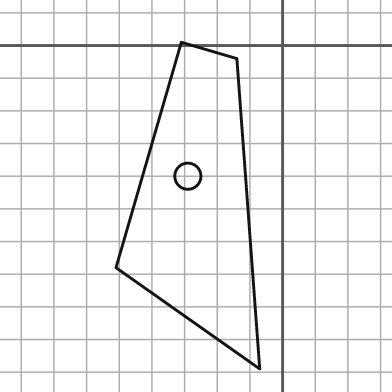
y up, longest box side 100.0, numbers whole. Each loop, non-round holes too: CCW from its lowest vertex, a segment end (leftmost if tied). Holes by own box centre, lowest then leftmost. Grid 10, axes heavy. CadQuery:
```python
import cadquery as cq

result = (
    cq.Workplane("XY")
    .moveTo(-7.0, -99.0)
    .lineTo(-14.0, -4.0)
    .lineTo(-31.0, 1.0)
    .lineTo(-51.0, -68.0)
    .close()
    .moveTo(-29.0, -40.0)
    .circle(4.0)
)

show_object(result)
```